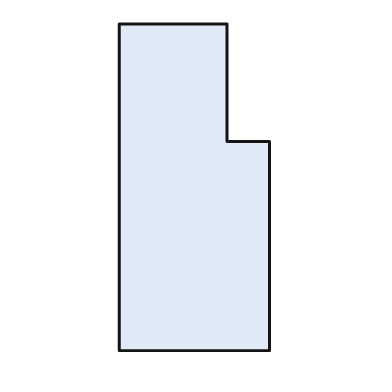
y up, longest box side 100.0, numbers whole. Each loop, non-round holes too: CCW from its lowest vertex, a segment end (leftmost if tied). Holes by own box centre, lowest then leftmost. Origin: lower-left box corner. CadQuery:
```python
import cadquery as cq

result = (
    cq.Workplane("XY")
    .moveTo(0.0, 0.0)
    .lineTo(46.0, 0.0)
    .lineTo(46.0, 64.0)
    .lineTo(33.0, 64.0)
    .lineTo(33.0, 100.0)
    .lineTo(0.0, 100.0)
    .close()
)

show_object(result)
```